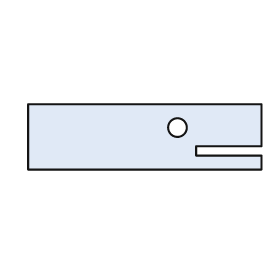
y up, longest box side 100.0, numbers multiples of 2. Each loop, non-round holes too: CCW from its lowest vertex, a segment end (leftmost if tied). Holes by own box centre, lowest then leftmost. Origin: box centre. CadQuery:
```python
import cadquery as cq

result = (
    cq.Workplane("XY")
    .moveTo(-50.0, -14.0)
    .lineTo(50.0, -14.0)
    .lineTo(50.0, -8.0)
    .lineTo(22.0, -8.0)
    .lineTo(22.0, -4.0)
    .lineTo(50.0, -4.0)
    .lineTo(50.0, 14.0)
    .lineTo(-50.0, 14.0)
    .close()
    .moveTo(14.0, 4.0)
    .circle(4.0)
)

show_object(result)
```